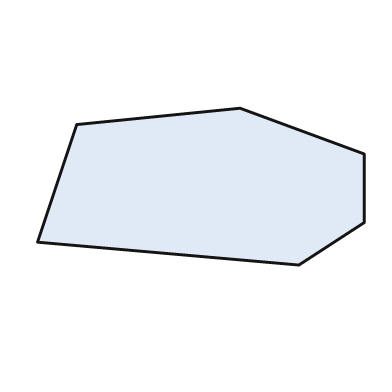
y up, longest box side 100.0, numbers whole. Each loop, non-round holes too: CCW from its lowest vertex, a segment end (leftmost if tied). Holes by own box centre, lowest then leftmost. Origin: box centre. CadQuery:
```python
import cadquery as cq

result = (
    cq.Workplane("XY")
    .moveTo(30.0, -24.0)
    .lineTo(50.0, -11.0)
    .lineTo(50.0, 10.0)
    .lineTo(12.0, 24.0)
    .lineTo(-38.0, 19.0)
    .lineTo(-50.0, -17.0)
    .close()
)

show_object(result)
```